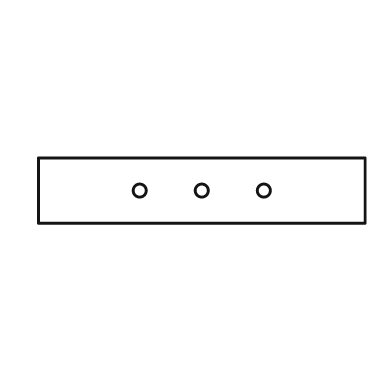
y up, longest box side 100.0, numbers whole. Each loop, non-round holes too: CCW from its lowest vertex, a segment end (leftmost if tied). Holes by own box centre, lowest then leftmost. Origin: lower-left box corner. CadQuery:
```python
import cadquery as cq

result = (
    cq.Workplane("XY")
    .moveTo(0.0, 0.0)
    .lineTo(100.0, 0.0)
    .lineTo(100.0, 20.0)
    .lineTo(0.0, 20.0)
    .close()
    .moveTo(31.0, 10.0)
    .circle(2.0)
    .moveTo(50.0, 10.0)
    .circle(2.0)
    .moveTo(69.0, 10.0)
    .circle(2.0)
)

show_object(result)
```